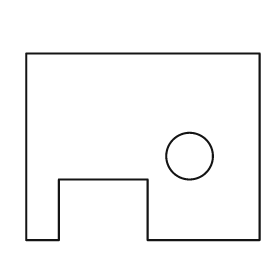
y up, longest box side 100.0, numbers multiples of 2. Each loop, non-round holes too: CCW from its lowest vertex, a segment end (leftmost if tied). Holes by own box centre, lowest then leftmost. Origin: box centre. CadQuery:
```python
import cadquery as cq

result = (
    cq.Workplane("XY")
    .moveTo(-50.0, -40.0)
    .lineTo(-36.0, -40.0)
    .lineTo(-36.0, -14.0)
    .lineTo(2.0, -14.0)
    .lineTo(2.0, -40.0)
    .lineTo(50.0, -40.0)
    .lineTo(50.0, 40.0)
    .lineTo(-50.0, 40.0)
    .close()
    .moveTo(20.0, -4.0)
    .circle(10.0)
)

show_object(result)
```